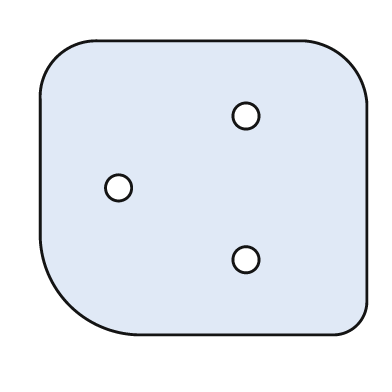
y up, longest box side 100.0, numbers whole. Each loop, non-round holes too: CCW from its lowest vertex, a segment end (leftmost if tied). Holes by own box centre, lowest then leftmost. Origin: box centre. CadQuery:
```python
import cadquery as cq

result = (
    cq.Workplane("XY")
    .moveTo(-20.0, -45.0)
    .lineTo(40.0, -45.0)
    .threePointArc((47.0, -42.0), (50.0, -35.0))
    .lineTo(50.0, 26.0)
    .threePointArc((44.0, 39.0), (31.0, 45.0))
    .lineTo(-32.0, 45.0)
    .threePointArc((-45.0, 40.0), (-50.0, 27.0))
    .lineTo(-50.0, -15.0)
    .threePointArc((-41.0, -36.0), (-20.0, -45.0))
    .close()
    .moveTo(13.0, -22.0)
    .circle(4.0)
    .moveTo(-26.0, 0.0)
    .circle(4.0)
    .moveTo(13.0, 22.0)
    .circle(4.0)
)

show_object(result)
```